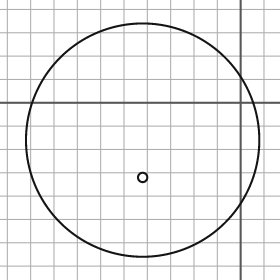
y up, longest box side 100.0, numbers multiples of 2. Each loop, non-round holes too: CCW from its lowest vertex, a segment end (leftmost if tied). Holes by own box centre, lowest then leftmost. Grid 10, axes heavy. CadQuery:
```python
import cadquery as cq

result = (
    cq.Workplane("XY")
    .moveTo(-42.0, -16.0)
    .circle(50.0)
    .moveTo(-42.0, -32.0)
    .circle(2.0)
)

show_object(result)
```